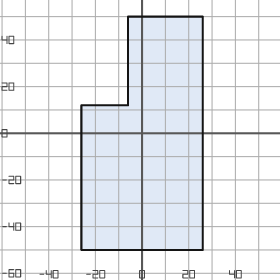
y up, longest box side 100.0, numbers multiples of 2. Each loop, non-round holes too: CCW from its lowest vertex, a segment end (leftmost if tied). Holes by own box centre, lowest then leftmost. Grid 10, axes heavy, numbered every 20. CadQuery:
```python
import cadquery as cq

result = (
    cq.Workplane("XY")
    .moveTo(-26.0, -50.0)
    .lineTo(26.0, -50.0)
    .lineTo(26.0, 50.0)
    .lineTo(-6.0, 50.0)
    .lineTo(-6.0, 12.0)
    .lineTo(-26.0, 12.0)
    .close()
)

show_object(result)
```